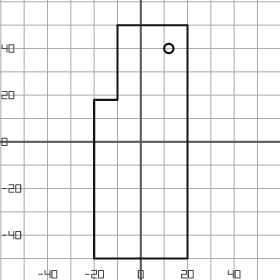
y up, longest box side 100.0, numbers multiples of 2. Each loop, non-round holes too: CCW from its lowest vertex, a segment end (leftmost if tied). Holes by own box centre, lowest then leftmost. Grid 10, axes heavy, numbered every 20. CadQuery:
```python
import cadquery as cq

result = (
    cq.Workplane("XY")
    .moveTo(-20.0, -50.0)
    .lineTo(20.0, -50.0)
    .lineTo(20.0, 50.0)
    .lineTo(-10.0, 50.0)
    .lineTo(-10.0, 18.0)
    .lineTo(-20.0, 18.0)
    .close()
    .moveTo(12.0, 40.0)
    .circle(2.0)
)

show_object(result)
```